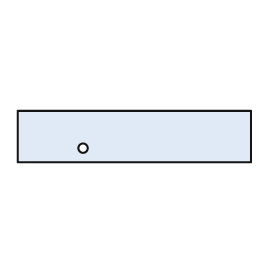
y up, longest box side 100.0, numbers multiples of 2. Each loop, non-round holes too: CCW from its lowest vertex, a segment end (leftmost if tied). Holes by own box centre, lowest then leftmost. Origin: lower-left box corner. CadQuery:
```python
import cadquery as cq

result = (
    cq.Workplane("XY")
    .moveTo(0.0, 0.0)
    .lineTo(100.0, 0.0)
    .lineTo(100.0, 22.0)
    .lineTo(0.0, 22.0)
    .close()
    .moveTo(28.0, 6.0)
    .circle(2.0)
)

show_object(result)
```